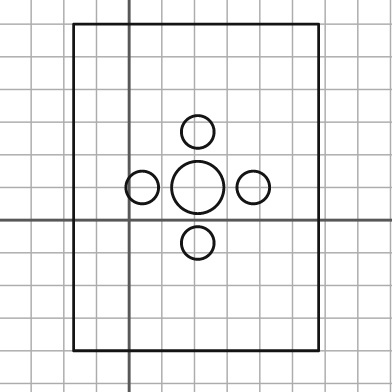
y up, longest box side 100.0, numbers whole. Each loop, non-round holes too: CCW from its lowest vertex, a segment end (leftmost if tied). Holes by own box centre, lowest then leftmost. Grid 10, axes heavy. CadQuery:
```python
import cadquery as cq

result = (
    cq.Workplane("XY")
    .moveTo(-17.0, -40.0)
    .lineTo(58.0, -40.0)
    .lineTo(58.0, 60.0)
    .lineTo(-17.0, 60.0)
    .close()
    .moveTo(21.0, -7.0)
    .circle(5.0)
    .moveTo(4.0, 10.0)
    .circle(5.0)
    .moveTo(21.0, 10.0)
    .circle(8.0)
    .moveTo(38.0, 10.0)
    .circle(5.0)
    .moveTo(21.0, 27.0)
    .circle(5.0)
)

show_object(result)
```